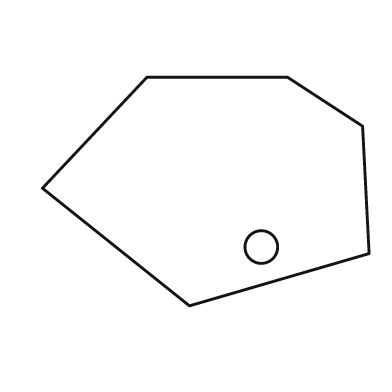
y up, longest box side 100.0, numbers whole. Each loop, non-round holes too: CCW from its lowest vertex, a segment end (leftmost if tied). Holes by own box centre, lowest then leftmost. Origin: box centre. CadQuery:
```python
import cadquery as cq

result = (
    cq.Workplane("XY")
    .moveTo(-5.0, -35.0)
    .lineTo(50.0, -19.0)
    .lineTo(48.0, 20.0)
    .lineTo(25.0, 35.0)
    .lineTo(-18.0, 35.0)
    .lineTo(-50.0, 1.0)
    .close()
    .moveTo(17.0, -17.0)
    .circle(5.0)
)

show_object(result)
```